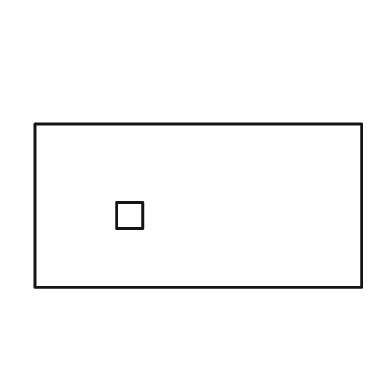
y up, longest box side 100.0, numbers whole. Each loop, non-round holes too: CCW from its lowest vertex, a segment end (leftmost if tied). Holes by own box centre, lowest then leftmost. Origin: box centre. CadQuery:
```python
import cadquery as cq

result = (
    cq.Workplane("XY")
    .moveTo(-50.0, -25.0)
    .lineTo(50.0, -25.0)
    .lineTo(50.0, 25.0)
    .lineTo(-50.0, 25.0)
    .close()
    .moveTo(-25.0, -7.0)
    .lineTo(-17.0, -7.0)
    .lineTo(-17.0, 1.0)
    .lineTo(-25.0, 1.0)
    .close()
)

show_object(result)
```